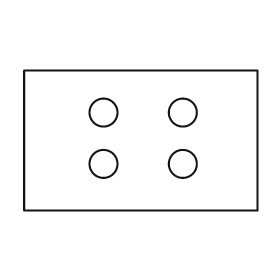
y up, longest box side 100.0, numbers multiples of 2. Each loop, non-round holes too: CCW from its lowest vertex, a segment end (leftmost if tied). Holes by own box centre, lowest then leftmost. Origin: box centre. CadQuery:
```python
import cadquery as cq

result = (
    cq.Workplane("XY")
    .moveTo(-50.0, -30.0)
    .lineTo(50.0, -30.0)
    .lineTo(50.0, 30.0)
    .lineTo(-50.0, 30.0)
    .close()
    .moveTo(-16.0, -10.0)
    .circle(6.0)
    .moveTo(18.0, -10.0)
    .circle(6.0)
    .moveTo(-16.0, 12.0)
    .circle(6.0)
    .moveTo(18.0, 12.0)
    .circle(6.0)
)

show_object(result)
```